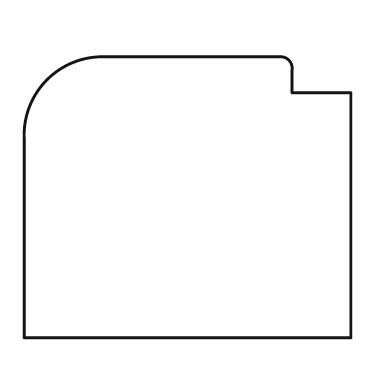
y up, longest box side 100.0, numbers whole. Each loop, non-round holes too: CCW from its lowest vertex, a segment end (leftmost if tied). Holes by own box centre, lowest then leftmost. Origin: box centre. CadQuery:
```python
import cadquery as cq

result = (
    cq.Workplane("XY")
    .moveTo(-50.0, -43.0)
    .lineTo(50.0, -43.0)
    .lineTo(50.0, 32.0)
    .lineTo(32.0, 32.0)
    .lineTo(32.0, 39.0)
    .threePointArc((31.0, 42.0), (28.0, 43.0))
    .lineTo(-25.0, 43.0)
    .threePointArc((-43.0, 36.0), (-50.0, 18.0))
    .close()
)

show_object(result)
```